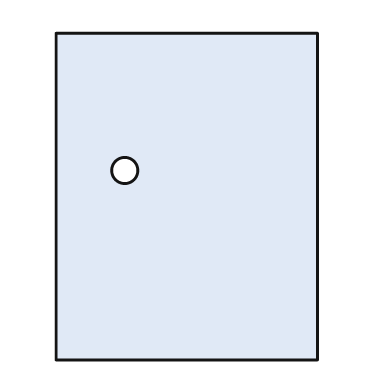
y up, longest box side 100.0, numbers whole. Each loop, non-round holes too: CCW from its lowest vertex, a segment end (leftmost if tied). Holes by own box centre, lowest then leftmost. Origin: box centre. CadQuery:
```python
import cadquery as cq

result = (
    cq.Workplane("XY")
    .moveTo(-40.0, -50.0)
    .lineTo(40.0, -50.0)
    .lineTo(40.0, 50.0)
    .lineTo(-40.0, 50.0)
    .close()
    .moveTo(-19.0, 8.0)
    .circle(4.0)
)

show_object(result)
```